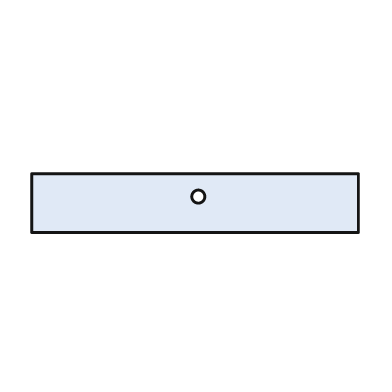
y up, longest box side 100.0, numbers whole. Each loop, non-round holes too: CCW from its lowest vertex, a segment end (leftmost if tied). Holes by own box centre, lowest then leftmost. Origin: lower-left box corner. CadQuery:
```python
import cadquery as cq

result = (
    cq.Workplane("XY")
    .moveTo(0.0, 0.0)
    .lineTo(100.0, 0.0)
    .lineTo(100.0, 18.0)
    .lineTo(0.0, 18.0)
    .close()
    .moveTo(51.0, 11.0)
    .circle(2.0)
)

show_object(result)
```